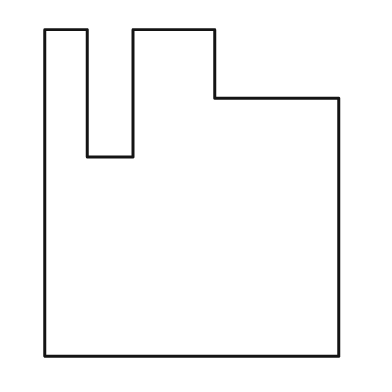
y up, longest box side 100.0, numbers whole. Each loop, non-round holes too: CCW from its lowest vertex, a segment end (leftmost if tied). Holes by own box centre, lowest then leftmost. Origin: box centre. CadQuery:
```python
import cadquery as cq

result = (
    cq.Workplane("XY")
    .moveTo(-45.0, -50.0)
    .lineTo(45.0, -50.0)
    .lineTo(45.0, 29.0)
    .lineTo(7.0, 29.0)
    .lineTo(7.0, 50.0)
    .lineTo(-18.0, 50.0)
    .lineTo(-18.0, 11.0)
    .lineTo(-32.0, 11.0)
    .lineTo(-32.0, 50.0)
    .lineTo(-45.0, 50.0)
    .close()
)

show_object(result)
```